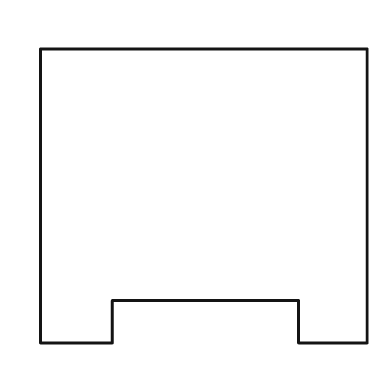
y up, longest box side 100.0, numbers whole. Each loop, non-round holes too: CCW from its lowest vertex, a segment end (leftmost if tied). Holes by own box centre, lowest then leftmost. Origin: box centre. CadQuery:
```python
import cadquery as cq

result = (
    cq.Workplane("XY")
    .moveTo(-50.0, -45.0)
    .lineTo(-28.0, -45.0)
    .lineTo(-28.0, -32.0)
    .lineTo(29.0, -32.0)
    .lineTo(29.0, -45.0)
    .lineTo(50.0, -45.0)
    .lineTo(50.0, 45.0)
    .lineTo(-50.0, 45.0)
    .close()
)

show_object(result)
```